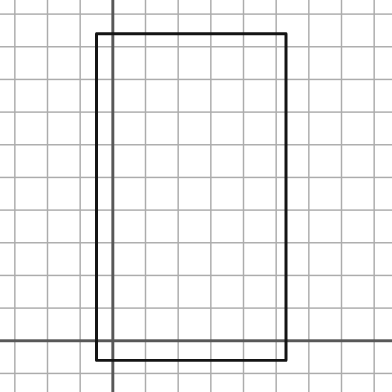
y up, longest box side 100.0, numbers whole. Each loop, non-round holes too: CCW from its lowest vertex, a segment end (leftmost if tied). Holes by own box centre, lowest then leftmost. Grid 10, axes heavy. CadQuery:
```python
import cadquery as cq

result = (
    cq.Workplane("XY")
    .moveTo(-5.0, -6.0)
    .lineTo(53.0, -6.0)
    .lineTo(53.0, 94.0)
    .lineTo(-5.0, 94.0)
    .close()
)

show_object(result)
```